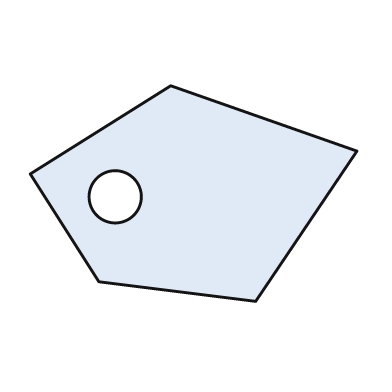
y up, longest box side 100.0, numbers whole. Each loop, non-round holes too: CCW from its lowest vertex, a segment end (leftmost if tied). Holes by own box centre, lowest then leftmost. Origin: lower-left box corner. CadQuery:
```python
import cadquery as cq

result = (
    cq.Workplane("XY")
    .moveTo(69.0, 0.0)
    .lineTo(100.0, 46.0)
    .lineTo(43.0, 66.0)
    .lineTo(0.0, 39.0)
    .lineTo(21.0, 6.0)
    .close()
    .moveTo(26.0, 32.0)
    .circle(8.0)
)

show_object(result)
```